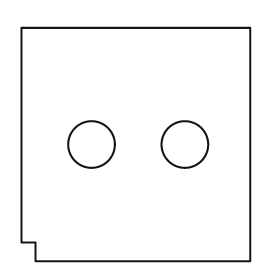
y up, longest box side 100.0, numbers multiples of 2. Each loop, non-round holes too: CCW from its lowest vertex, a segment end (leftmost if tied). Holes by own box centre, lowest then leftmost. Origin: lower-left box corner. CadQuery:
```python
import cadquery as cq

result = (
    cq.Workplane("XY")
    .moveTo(6.0, 0.0)
    .lineTo(98.0, 0.0)
    .lineTo(98.0, 100.0)
    .lineTo(0.0, 100.0)
    .lineTo(0.0, 8.0)
    .lineTo(6.0, 8.0)
    .close()
    .moveTo(30.0, 50.0)
    .circle(10.0)
    .moveTo(70.0, 50.0)
    .circle(10.0)
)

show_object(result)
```